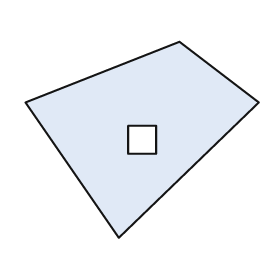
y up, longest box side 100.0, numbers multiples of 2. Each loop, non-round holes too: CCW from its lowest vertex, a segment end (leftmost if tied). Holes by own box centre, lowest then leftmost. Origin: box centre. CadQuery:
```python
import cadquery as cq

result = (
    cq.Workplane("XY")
    .moveTo(-10.0, -42.0)
    .lineTo(50.0, 16.0)
    .lineTo(16.0, 42.0)
    .lineTo(-50.0, 16.0)
    .close()
    .moveTo(-6.0, -6.0)
    .lineTo(6.0, -6.0)
    .lineTo(6.0, 6.0)
    .lineTo(-6.0, 6.0)
    .close()
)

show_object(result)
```